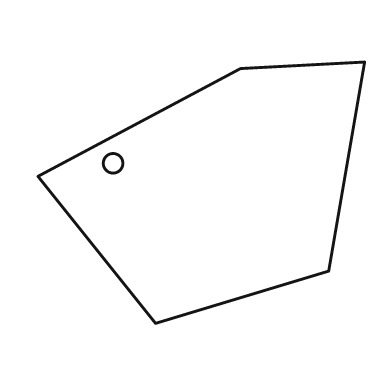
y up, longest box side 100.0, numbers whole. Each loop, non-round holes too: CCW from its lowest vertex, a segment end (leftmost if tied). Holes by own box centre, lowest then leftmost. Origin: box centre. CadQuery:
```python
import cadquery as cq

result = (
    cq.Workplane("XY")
    .moveTo(-14.0, -40.0)
    .lineTo(39.0, -24.0)
    .lineTo(50.0, 40.0)
    .lineTo(12.0, 38.0)
    .lineTo(-50.0, 5.0)
    .close()
    .moveTo(-27.0, 9.0)
    .circle(3.0)
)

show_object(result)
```